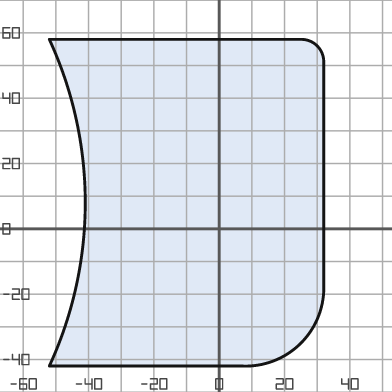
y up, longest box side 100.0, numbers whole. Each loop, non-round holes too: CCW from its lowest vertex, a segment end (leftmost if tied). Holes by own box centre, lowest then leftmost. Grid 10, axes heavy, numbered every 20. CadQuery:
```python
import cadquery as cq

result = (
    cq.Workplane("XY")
    .moveTo(-52.0, -42.0)
    .lineTo(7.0, -42.0)
    .threePointArc((25.0, -35.0), (32.0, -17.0))
    .lineTo(32.0, 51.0)
    .threePointArc((30.0, 56.0), (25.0, 58.0))
    .lineTo(-52.0, 58.0)
    .threePointArc((-41.0, 8.0), (-52.0, -42.0))
    .close()
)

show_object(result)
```